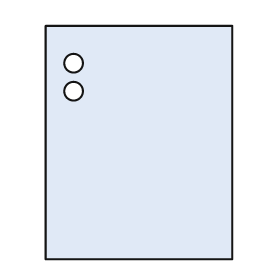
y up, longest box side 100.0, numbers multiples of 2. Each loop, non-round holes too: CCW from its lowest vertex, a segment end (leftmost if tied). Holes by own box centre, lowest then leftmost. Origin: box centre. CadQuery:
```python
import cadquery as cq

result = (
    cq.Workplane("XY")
    .moveTo(-40.0, -50.0)
    .lineTo(40.0, -50.0)
    .lineTo(40.0, 50.0)
    .lineTo(-40.0, 50.0)
    .close()
    .moveTo(-28.0, 22.0)
    .circle(4.0)
    .moveTo(-28.0, 34.0)
    .circle(4.0)
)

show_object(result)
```